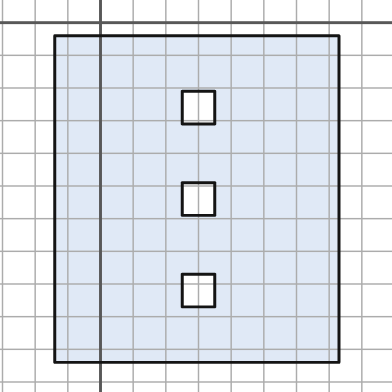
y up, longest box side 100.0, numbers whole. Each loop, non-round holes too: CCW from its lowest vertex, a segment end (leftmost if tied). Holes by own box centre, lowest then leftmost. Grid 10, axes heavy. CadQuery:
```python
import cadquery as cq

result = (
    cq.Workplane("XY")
    .moveTo(-14.0, -104.0)
    .lineTo(73.0, -104.0)
    .lineTo(73.0, -4.0)
    .lineTo(-14.0, -4.0)
    .close()
    .moveTo(25.0, -87.0)
    .lineTo(35.0, -87.0)
    .lineTo(35.0, -77.0)
    .lineTo(25.0, -77.0)
    .close()
    .moveTo(25.0, -59.0)
    .lineTo(35.0, -59.0)
    .lineTo(35.0, -49.0)
    .lineTo(25.0, -49.0)
    .close()
    .moveTo(25.0, -31.0)
    .lineTo(35.0, -31.0)
    .lineTo(35.0, -21.0)
    .lineTo(25.0, -21.0)
    .close()
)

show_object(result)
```